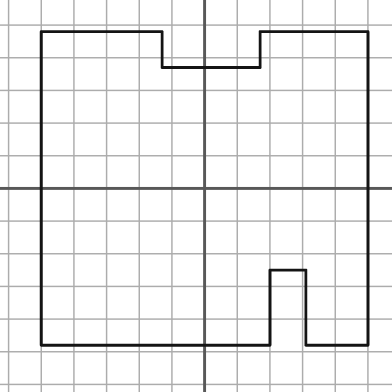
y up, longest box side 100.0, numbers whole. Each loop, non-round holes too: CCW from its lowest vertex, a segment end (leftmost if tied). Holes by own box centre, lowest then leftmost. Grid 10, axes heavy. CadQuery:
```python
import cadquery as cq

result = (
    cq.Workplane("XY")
    .moveTo(-50.0, -48.0)
    .lineTo(20.0, -48.0)
    .lineTo(20.0, -25.0)
    .lineTo(31.0, -25.0)
    .lineTo(31.0, -48.0)
    .lineTo(50.0, -48.0)
    .lineTo(50.0, 48.0)
    .lineTo(17.0, 48.0)
    .lineTo(17.0, 37.0)
    .lineTo(-13.0, 37.0)
    .lineTo(-13.0, 48.0)
    .lineTo(-50.0, 48.0)
    .close()
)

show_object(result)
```